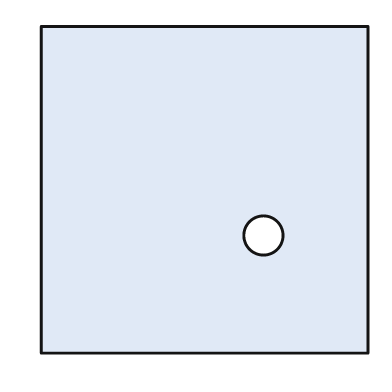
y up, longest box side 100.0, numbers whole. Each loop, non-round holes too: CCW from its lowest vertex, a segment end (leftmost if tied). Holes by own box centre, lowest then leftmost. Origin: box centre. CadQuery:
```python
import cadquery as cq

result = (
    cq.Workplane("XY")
    .moveTo(-50.0, -50.0)
    .lineTo(50.0, -50.0)
    .lineTo(50.0, 50.0)
    .lineTo(-50.0, 50.0)
    .close()
    .moveTo(18.0, -14.0)
    .circle(6.0)
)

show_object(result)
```